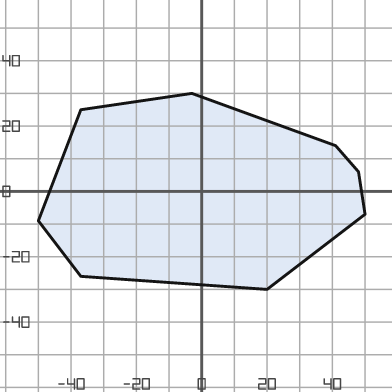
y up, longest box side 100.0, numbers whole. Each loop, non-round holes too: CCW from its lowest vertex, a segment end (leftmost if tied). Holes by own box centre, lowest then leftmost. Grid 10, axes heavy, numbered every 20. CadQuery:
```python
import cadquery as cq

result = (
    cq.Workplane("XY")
    .moveTo(20.0, -30.0)
    .lineTo(50.0, -7.0)
    .lineTo(48.0, 6.0)
    .lineTo(41.0, 14.0)
    .lineTo(-3.0, 30.0)
    .lineTo(-37.0, 25.0)
    .lineTo(-50.0, -9.0)
    .lineTo(-37.0, -26.0)
    .close()
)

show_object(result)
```